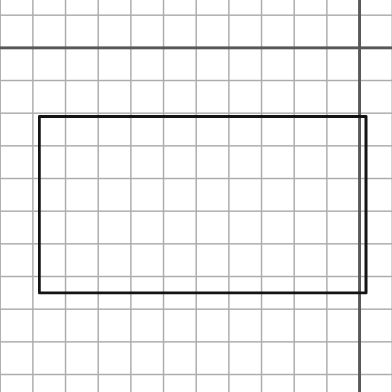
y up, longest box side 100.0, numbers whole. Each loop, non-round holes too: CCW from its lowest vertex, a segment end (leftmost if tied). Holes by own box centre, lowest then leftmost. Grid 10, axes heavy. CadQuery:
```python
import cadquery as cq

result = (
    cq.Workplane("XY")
    .moveTo(-98.0, -75.0)
    .lineTo(2.0, -75.0)
    .lineTo(2.0, -21.0)
    .lineTo(-98.0, -21.0)
    .close()
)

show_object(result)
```